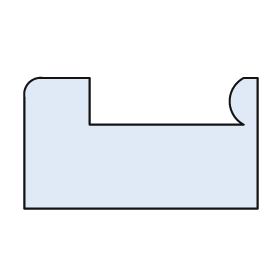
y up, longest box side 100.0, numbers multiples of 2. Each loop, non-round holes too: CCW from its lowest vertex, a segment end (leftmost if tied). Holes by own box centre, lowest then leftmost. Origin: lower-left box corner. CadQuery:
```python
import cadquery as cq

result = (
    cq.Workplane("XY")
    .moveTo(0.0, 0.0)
    .lineTo(100.0, 0.0)
    .lineTo(100.0, 56.0)
    .lineTo(94.0, 56.0)
    .threePointArc((88.0, 46.0), (94.0, 36.0))
    .lineTo(28.0, 36.0)
    .lineTo(28.0, 56.0)
    .lineTo(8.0, 56.0)
    .threePointArc((2.0, 54.0), (0.0, 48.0))
    .close()
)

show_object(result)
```